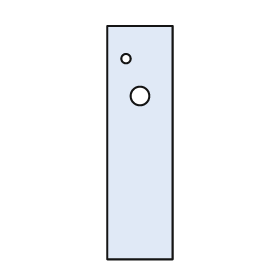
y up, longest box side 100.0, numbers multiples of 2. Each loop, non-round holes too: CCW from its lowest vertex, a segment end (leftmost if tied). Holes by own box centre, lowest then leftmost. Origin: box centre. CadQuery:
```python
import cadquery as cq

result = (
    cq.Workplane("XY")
    .moveTo(-14.0, -50.0)
    .lineTo(14.0, -50.0)
    .lineTo(14.0, 50.0)
    .lineTo(-14.0, 50.0)
    .close()
    .moveTo(0.0, 20.0)
    .circle(4.0)
    .moveTo(-6.0, 36.0)
    .circle(2.0)
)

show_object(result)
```